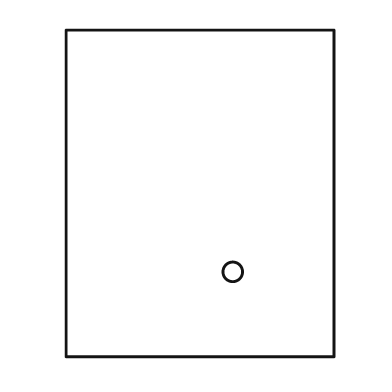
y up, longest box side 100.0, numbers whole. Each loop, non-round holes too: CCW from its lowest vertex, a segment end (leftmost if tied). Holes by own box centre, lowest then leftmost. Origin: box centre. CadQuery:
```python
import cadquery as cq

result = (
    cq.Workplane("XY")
    .moveTo(-41.0, -50.0)
    .lineTo(41.0, -50.0)
    .lineTo(41.0, 50.0)
    .lineTo(-41.0, 50.0)
    .close()
    .moveTo(10.0, -24.0)
    .circle(3.0)
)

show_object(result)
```